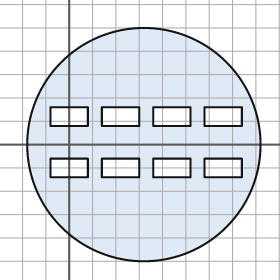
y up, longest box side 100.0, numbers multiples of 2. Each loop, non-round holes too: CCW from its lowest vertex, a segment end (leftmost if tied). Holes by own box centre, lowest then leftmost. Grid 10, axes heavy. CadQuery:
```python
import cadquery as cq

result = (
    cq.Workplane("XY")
    .moveTo(32.0, 0.0)
    .circle(50.0)
    .moveTo(-8.0, -14.0)
    .lineTo(8.0, -14.0)
    .lineTo(8.0, -6.0)
    .lineTo(-8.0, -6.0)
    .close()
    .moveTo(14.0, -14.0)
    .lineTo(30.0, -14.0)
    .lineTo(30.0, -6.0)
    .lineTo(14.0, -6.0)
    .close()
    .moveTo(36.0, -14.0)
    .lineTo(52.0, -14.0)
    .lineTo(52.0, -6.0)
    .lineTo(36.0, -6.0)
    .close()
    .moveTo(58.0, -14.0)
    .lineTo(74.0, -14.0)
    .lineTo(74.0, -6.0)
    .lineTo(58.0, -6.0)
    .close()
    .moveTo(-8.0, 8.0)
    .lineTo(8.0, 8.0)
    .lineTo(8.0, 16.0)
    .lineTo(-8.0, 16.0)
    .close()
    .moveTo(14.0, 8.0)
    .lineTo(30.0, 8.0)
    .lineTo(30.0, 16.0)
    .lineTo(14.0, 16.0)
    .close()
    .moveTo(36.0, 8.0)
    .lineTo(52.0, 8.0)
    .lineTo(52.0, 16.0)
    .lineTo(36.0, 16.0)
    .close()
    .moveTo(58.0, 8.0)
    .lineTo(74.0, 8.0)
    .lineTo(74.0, 16.0)
    .lineTo(58.0, 16.0)
    .close()
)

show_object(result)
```